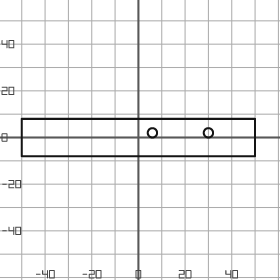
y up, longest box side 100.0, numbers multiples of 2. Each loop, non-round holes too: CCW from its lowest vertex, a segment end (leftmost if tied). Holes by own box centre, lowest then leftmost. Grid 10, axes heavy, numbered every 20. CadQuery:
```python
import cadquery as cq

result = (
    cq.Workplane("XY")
    .moveTo(-50.0, -8.0)
    .lineTo(50.0, -8.0)
    .lineTo(50.0, 8.0)
    .lineTo(-50.0, 8.0)
    .close()
    .moveTo(6.0, 2.0)
    .circle(2.0)
    .moveTo(30.0, 2.0)
    .circle(2.0)
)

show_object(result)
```